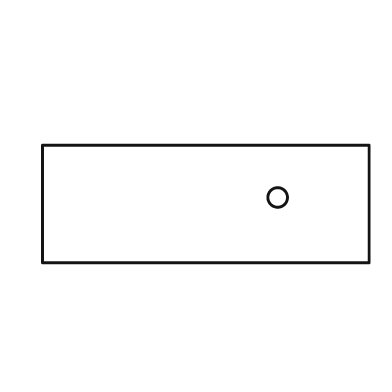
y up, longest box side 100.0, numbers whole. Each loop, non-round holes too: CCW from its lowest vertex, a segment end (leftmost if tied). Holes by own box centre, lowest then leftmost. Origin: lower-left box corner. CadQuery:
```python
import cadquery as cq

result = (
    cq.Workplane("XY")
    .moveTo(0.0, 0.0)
    .lineTo(100.0, 0.0)
    .lineTo(100.0, 36.0)
    .lineTo(0.0, 36.0)
    .close()
    .moveTo(72.0, 20.0)
    .circle(3.0)
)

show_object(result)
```